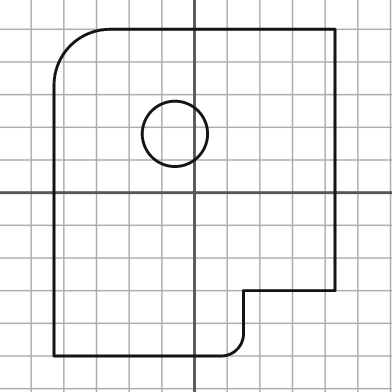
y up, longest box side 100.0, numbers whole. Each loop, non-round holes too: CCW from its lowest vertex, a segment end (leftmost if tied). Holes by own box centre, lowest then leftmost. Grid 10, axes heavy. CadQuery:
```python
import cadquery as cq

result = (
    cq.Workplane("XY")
    .moveTo(-43.0, -50.0)
    .lineTo(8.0, -50.0)
    .threePointArc((13.0, -48.0), (15.0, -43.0))
    .lineTo(15.0, -30.0)
    .lineTo(43.0, -30.0)
    .lineTo(43.0, 50.0)
    .lineTo(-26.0, 50.0)
    .threePointArc((-38.0, 45.0), (-43.0, 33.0))
    .close()
    .moveTo(-6.0, 18.0)
    .circle(10.0)
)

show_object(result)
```